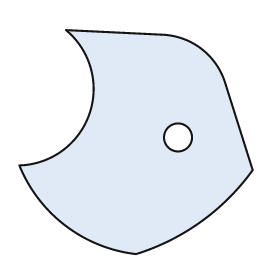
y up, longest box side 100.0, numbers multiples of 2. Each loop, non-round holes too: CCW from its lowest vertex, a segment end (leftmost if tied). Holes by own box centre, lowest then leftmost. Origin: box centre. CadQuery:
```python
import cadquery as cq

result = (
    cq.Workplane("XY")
    .moveTo(0.0, -48.0)
    .threePointArc((28.0, -34.0), (50.0, -12.0))
    .lineTo(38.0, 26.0)
    .threePointArc((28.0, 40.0), (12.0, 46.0))
    .lineTo(-30.0, 48.0)
    .threePointArc((-20.0, 12.0), (-50.0, -10.0))
    .threePointArc((-30.0, -36.0), (0.0, -48.0))
    .close()
    .moveTo(18.0, 2.0)
    .circle(6.0)
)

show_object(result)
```